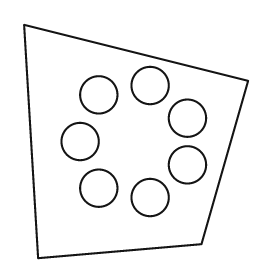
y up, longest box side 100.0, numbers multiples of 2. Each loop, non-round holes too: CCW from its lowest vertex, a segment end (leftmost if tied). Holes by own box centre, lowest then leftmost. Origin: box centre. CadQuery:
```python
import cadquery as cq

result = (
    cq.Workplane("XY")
    .moveTo(-42.0, -50.0)
    .lineTo(28.0, -44.0)
    .lineTo(48.0, 26.0)
    .lineTo(-48.0, 50.0)
    .close()
    .moveTo(6.0, -24.0)
    .circle(8.0)
    .moveTo(-16.0, -20.0)
    .circle(8.0)
    .moveTo(22.0, -10.0)
    .circle(8.0)
    .moveTo(-24.0, 0.0)
    .circle(8.0)
    .moveTo(22.0, 10.0)
    .circle(8.0)
    .moveTo(-16.0, 20.0)
    .circle(8.0)
    .moveTo(6.0, 24.0)
    .circle(8.0)
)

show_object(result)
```